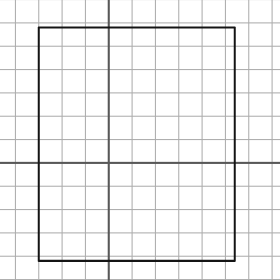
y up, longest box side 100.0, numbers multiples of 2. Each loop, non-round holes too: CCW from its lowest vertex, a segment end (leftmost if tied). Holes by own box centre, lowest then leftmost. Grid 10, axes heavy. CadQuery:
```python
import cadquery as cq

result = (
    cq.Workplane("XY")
    .moveTo(-30.0, -42.0)
    .lineTo(54.0, -42.0)
    .lineTo(54.0, 58.0)
    .lineTo(-30.0, 58.0)
    .close()
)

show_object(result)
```